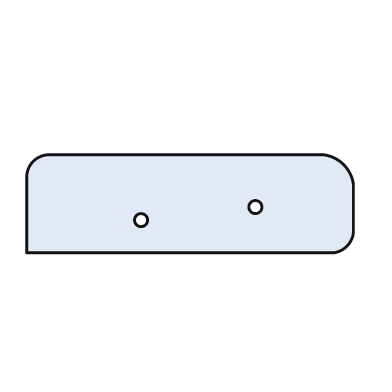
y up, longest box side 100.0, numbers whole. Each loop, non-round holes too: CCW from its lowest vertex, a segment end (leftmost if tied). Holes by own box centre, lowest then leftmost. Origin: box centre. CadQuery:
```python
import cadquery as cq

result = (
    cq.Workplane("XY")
    .moveTo(-50.0, -15.0)
    .lineTo(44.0, -15.0)
    .threePointArc((48.0, -13.0), (50.0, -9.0))
    .lineTo(50.0, 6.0)
    .threePointArc((47.0, 12.0), (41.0, 15.0))
    .lineTo(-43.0, 15.0)
    .threePointArc((-48.0, 13.0), (-50.0, 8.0))
    .close()
    .moveTo(-15.0, -5.0)
    .circle(2.0)
    .moveTo(20.0, -1.0)
    .circle(2.0)
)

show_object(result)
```